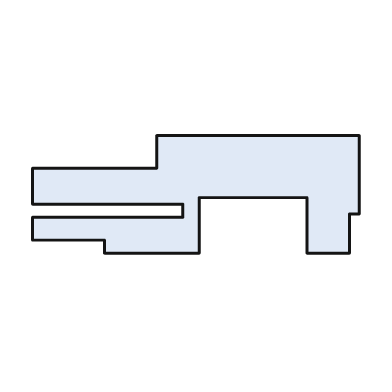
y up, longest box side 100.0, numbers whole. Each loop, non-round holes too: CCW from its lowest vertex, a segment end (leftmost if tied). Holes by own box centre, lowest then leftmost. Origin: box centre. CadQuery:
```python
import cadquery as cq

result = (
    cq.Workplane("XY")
    .moveTo(-28.0, -18.0)
    .lineTo(1.0, -18.0)
    .lineTo(1.0, -1.0)
    .lineTo(34.0, -1.0)
    .lineTo(34.0, -18.0)
    .lineTo(47.0, -18.0)
    .lineTo(47.0, -6.0)
    .lineTo(50.0, -6.0)
    .lineTo(50.0, 18.0)
    .lineTo(-12.0, 18.0)
    .lineTo(-12.0, 8.0)
    .lineTo(-50.0, 8.0)
    .lineTo(-50.0, -3.0)
    .lineTo(-4.0, -3.0)
    .lineTo(-4.0, -7.0)
    .lineTo(-50.0, -7.0)
    .lineTo(-50.0, -14.0)
    .lineTo(-28.0, -14.0)
    .close()
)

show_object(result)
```